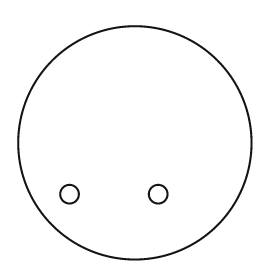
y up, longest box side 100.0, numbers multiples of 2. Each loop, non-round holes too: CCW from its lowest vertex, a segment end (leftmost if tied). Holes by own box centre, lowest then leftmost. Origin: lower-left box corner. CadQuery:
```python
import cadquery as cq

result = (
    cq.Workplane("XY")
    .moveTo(50.0, 50.0)
    .circle(50.0)
    .moveTo(22.0, 28.0)
    .circle(4.0)
    .moveTo(60.0, 28.0)
    .circle(4.0)
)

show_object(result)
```